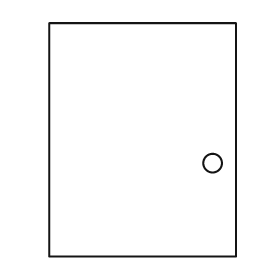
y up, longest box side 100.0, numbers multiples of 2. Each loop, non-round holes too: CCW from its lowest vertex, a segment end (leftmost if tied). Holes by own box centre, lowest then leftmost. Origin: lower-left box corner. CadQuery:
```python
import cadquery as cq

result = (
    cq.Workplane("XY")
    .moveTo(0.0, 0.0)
    .lineTo(80.0, 0.0)
    .lineTo(80.0, 100.0)
    .lineTo(0.0, 100.0)
    .close()
    .moveTo(70.0, 40.0)
    .circle(4.0)
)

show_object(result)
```